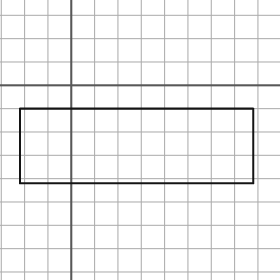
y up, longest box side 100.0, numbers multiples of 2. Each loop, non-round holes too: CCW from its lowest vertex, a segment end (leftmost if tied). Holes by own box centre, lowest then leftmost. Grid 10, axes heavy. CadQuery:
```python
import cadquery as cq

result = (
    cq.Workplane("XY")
    .moveTo(-22.0, -42.0)
    .lineTo(78.0, -42.0)
    .lineTo(78.0, -10.0)
    .lineTo(-22.0, -10.0)
    .close()
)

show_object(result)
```